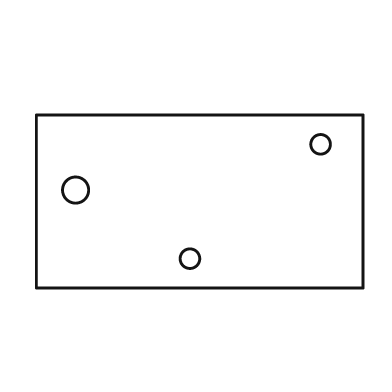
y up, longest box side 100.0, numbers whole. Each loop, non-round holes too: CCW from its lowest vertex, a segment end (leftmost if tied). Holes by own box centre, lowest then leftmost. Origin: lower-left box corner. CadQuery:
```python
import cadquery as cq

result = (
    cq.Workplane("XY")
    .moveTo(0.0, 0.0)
    .lineTo(100.0, 0.0)
    .lineTo(100.0, 53.0)
    .lineTo(0.0, 53.0)
    .close()
    .moveTo(47.0, 9.0)
    .circle(3.0)
    .moveTo(12.0, 30.0)
    .circle(4.0)
    .moveTo(87.0, 44.0)
    .circle(3.0)
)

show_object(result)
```